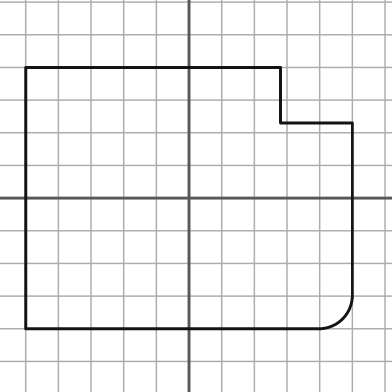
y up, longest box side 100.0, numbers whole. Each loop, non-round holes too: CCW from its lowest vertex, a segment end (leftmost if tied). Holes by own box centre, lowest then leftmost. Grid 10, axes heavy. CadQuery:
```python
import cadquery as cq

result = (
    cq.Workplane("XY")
    .moveTo(-50.0, -40.0)
    .lineTo(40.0, -40.0)
    .threePointArc((47.0, -37.0), (50.0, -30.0))
    .lineTo(50.0, 23.0)
    .lineTo(28.0, 23.0)
    .lineTo(28.0, 40.0)
    .lineTo(-50.0, 40.0)
    .close()
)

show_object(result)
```